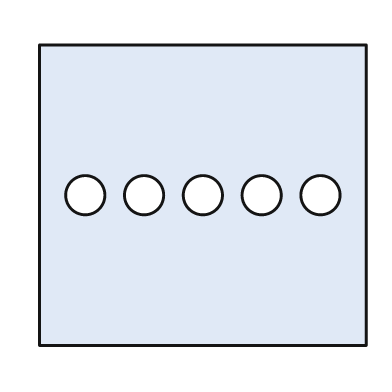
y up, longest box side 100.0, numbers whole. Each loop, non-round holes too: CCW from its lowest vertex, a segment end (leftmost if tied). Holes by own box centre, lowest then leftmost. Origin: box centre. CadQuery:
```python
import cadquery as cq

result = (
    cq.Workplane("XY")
    .moveTo(-50.0, -46.0)
    .lineTo(50.0, -46.0)
    .lineTo(50.0, 46.0)
    .lineTo(-50.0, 46.0)
    .close()
    .moveTo(-36.0, 0.0)
    .circle(6.0)
    .moveTo(-18.0, 0.0)
    .circle(6.0)
    .moveTo(0.0, 0.0)
    .circle(6.0)
    .moveTo(18.0, 0.0)
    .circle(6.0)
    .moveTo(36.0, 0.0)
    .circle(6.0)
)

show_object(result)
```